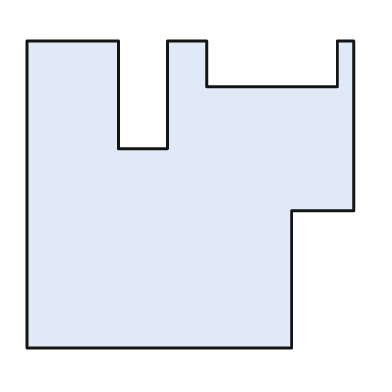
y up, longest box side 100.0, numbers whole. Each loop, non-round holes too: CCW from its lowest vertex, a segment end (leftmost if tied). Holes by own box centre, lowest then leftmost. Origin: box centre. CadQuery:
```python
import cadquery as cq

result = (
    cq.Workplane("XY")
    .moveTo(-50.0, -47.0)
    .lineTo(31.0, -47.0)
    .lineTo(31.0, -5.0)
    .lineTo(50.0, -5.0)
    .lineTo(50.0, 47.0)
    .lineTo(45.0, 47.0)
    .lineTo(45.0, 33.0)
    .lineTo(5.0, 33.0)
    .lineTo(5.0, 47.0)
    .lineTo(-7.0, 47.0)
    .lineTo(-7.0, 14.0)
    .lineTo(-22.0, 14.0)
    .lineTo(-22.0, 47.0)
    .lineTo(-50.0, 47.0)
    .close()
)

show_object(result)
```